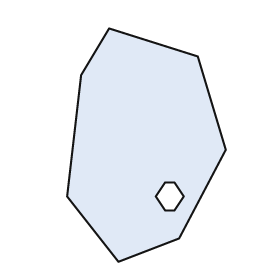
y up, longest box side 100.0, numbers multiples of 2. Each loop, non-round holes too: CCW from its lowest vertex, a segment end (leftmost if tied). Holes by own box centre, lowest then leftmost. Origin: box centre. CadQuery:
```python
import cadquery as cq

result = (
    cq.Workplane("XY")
    .moveTo(-12.0, -50.0)
    .lineTo(14.0, -40.0)
    .lineTo(34.0, -2.0)
    .lineTo(22.0, 38.0)
    .lineTo(-16.0, 50.0)
    .lineTo(-28.0, 30.0)
    .lineTo(-34.0, -22.0)
    .close()
    .moveTo(8.0, -28.0)
    .lineTo(12.0, -28.0)
    .lineTo(16.0, -22.0)
    .lineTo(12.0, -16.0)
    .lineTo(8.0, -16.0)
    .lineTo(4.0, -22.0)
    .close()
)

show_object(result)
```